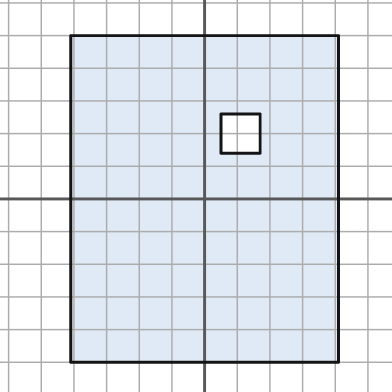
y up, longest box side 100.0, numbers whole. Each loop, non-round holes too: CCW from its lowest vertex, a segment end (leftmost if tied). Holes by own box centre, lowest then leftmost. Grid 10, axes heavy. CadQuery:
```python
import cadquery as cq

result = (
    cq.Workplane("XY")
    .moveTo(-41.0, -50.0)
    .lineTo(41.0, -50.0)
    .lineTo(41.0, 50.0)
    .lineTo(-41.0, 50.0)
    .close()
    .moveTo(5.0, 14.0)
    .lineTo(17.0, 14.0)
    .lineTo(17.0, 26.0)
    .lineTo(5.0, 26.0)
    .close()
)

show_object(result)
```